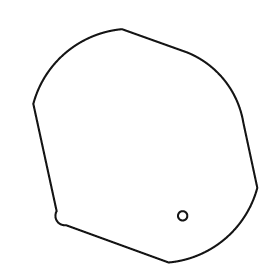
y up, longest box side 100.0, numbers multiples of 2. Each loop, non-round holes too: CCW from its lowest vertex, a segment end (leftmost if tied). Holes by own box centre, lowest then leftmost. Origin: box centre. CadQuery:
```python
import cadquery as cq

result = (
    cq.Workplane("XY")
    .moveTo(10.0, -50.0)
    .threePointArc((34.0, -40.0), (48.0, -18.0))
    .lineTo(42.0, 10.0)
    .threePointArc((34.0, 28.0), (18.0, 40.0))
    .lineTo(-10.0, 50.0)
    .threePointArc((-34.0, 40.0), (-48.0, 18.0))
    .lineTo(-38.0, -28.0)
    .threePointArc((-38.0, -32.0), (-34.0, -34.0))
    .close()
    .moveTo(16.0, -30.0)
    .circle(2.0)
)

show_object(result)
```